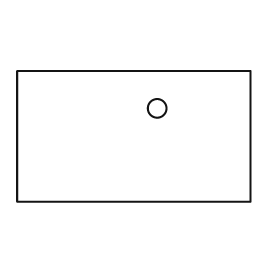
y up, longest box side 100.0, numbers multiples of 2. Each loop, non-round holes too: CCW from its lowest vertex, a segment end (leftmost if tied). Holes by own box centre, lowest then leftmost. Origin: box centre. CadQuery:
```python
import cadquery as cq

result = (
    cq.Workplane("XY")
    .moveTo(-50.0, -28.0)
    .lineTo(50.0, -28.0)
    .lineTo(50.0, 28.0)
    .lineTo(-50.0, 28.0)
    .close()
    .moveTo(10.0, 12.0)
    .circle(4.0)
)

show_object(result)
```